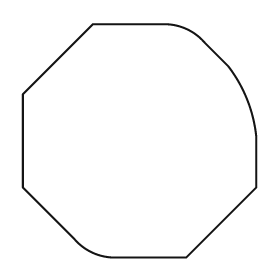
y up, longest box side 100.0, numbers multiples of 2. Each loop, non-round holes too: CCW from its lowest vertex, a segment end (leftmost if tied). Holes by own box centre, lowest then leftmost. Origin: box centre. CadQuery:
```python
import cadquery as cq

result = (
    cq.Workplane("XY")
    .moveTo(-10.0, -50.0)
    .lineTo(20.0, -50.0)
    .lineTo(50.0, -20.0)
    .lineTo(50.0, 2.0)
    .threePointArc((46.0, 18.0), (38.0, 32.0))
    .lineTo(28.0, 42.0)
    .threePointArc((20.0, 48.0), (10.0, 50.0))
    .lineTo(-20.0, 50.0)
    .lineTo(-50.0, 20.0)
    .lineTo(-50.0, -20.0)
    .lineTo(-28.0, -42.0)
    .threePointArc((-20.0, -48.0), (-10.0, -50.0))
    .close()
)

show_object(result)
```